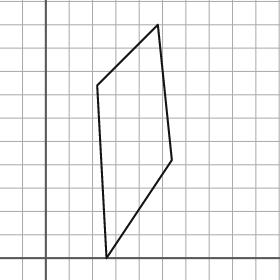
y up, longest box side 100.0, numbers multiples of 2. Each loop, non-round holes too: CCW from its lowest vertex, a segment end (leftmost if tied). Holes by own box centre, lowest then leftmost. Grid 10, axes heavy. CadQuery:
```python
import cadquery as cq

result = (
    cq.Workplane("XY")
    .moveTo(26.0, 0.0)
    .lineTo(54.0, 42.0)
    .lineTo(48.0, 100.0)
    .lineTo(22.0, 74.0)
    .close()
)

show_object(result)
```